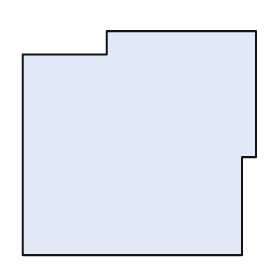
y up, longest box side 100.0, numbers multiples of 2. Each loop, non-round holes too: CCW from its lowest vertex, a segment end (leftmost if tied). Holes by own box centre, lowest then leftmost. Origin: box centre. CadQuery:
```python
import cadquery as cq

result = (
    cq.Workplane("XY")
    .moveTo(-50.0, -48.0)
    .lineTo(44.0, -48.0)
    .lineTo(44.0, -6.0)
    .lineTo(50.0, -6.0)
    .lineTo(50.0, 48.0)
    .lineTo(-14.0, 48.0)
    .lineTo(-14.0, 38.0)
    .lineTo(-50.0, 38.0)
    .close()
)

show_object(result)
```